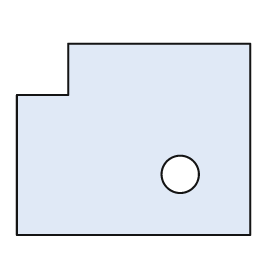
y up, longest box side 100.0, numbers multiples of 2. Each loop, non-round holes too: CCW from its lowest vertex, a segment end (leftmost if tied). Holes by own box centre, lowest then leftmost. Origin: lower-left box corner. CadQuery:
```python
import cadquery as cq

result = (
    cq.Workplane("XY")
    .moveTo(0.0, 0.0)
    .lineTo(100.0, 0.0)
    .lineTo(100.0, 82.0)
    .lineTo(22.0, 82.0)
    .lineTo(22.0, 60.0)
    .lineTo(0.0, 60.0)
    .close()
    .moveTo(70.0, 26.0)
    .circle(8.0)
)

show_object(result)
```